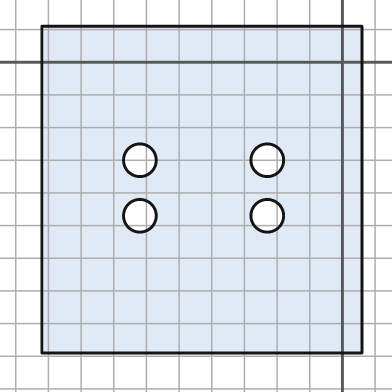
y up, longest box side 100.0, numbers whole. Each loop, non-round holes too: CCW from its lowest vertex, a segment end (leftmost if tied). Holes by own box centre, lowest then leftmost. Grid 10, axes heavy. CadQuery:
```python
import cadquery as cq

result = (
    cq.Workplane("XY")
    .moveTo(-92.0, -89.0)
    .lineTo(6.0, -89.0)
    .lineTo(6.0, 11.0)
    .lineTo(-92.0, 11.0)
    .close()
    .moveTo(-62.0, -47.0)
    .circle(5.0)
    .moveTo(-23.0, -47.0)
    .circle(5.0)
    .moveTo(-62.0, -30.0)
    .circle(5.0)
    .moveTo(-23.0, -30.0)
    .circle(5.0)
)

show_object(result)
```